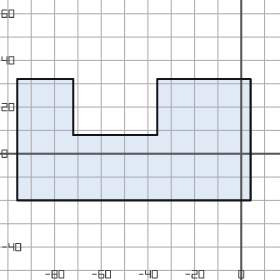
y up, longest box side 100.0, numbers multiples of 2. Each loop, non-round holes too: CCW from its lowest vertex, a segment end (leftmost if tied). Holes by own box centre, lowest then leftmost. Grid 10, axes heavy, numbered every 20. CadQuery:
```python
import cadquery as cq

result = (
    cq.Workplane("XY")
    .moveTo(-96.0, -20.0)
    .lineTo(4.0, -20.0)
    .lineTo(4.0, 32.0)
    .lineTo(-36.0, 32.0)
    .lineTo(-36.0, 8.0)
    .lineTo(-72.0, 8.0)
    .lineTo(-72.0, 32.0)
    .lineTo(-96.0, 32.0)
    .close()
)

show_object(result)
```